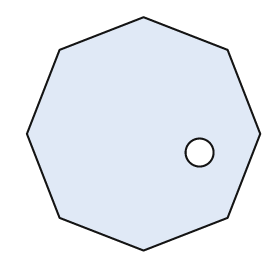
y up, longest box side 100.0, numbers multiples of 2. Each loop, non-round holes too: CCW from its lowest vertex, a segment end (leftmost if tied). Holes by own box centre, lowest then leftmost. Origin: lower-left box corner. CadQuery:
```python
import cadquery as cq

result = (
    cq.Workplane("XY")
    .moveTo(50.0, 0.0)
    .lineTo(86.0, 14.0)
    .lineTo(100.0, 50.0)
    .lineTo(86.0, 86.0)
    .lineTo(50.0, 100.0)
    .lineTo(14.0, 86.0)
    .lineTo(0.0, 50.0)
    .lineTo(14.0, 14.0)
    .close()
    .moveTo(74.0, 42.0)
    .circle(6.0)
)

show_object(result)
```